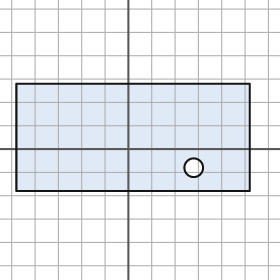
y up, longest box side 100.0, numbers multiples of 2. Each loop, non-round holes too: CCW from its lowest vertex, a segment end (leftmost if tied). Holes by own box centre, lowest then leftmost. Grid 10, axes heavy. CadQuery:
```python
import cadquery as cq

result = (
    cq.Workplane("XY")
    .moveTo(-48.0, -18.0)
    .lineTo(52.0, -18.0)
    .lineTo(52.0, 28.0)
    .lineTo(-48.0, 28.0)
    .close()
    .moveTo(28.0, -8.0)
    .circle(4.0)
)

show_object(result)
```